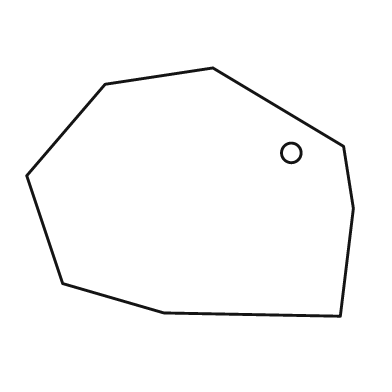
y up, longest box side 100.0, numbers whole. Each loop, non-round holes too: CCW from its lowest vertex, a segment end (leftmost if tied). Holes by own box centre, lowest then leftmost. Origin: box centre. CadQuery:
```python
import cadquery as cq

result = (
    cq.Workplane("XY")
    .moveTo(46.0, -38.0)
    .lineTo(50.0, -5.0)
    .lineTo(47.0, 14.0)
    .lineTo(7.0, 38.0)
    .lineTo(-26.0, 33.0)
    .lineTo(-50.0, 5.0)
    .lineTo(-39.0, -28.0)
    .lineTo(-8.0, -37.0)
    .close()
    .moveTo(31.0, 12.0)
    .circle(3.0)
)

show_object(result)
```